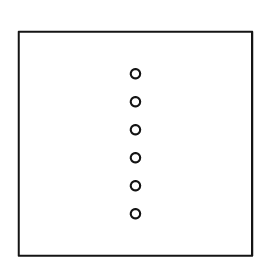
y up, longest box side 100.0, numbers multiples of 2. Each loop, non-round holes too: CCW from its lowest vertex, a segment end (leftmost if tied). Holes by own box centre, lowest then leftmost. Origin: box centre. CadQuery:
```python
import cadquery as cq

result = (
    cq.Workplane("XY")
    .moveTo(-50.0, -48.0)
    .lineTo(50.0, -48.0)
    .lineTo(50.0, 48.0)
    .lineTo(-50.0, 48.0)
    .close()
    .moveTo(0.0, -30.0)
    .circle(2.0)
    .moveTo(0.0, -18.0)
    .circle(2.0)
    .moveTo(0.0, -6.0)
    .circle(2.0)
    .moveTo(0.0, 6.0)
    .circle(2.0)
    .moveTo(0.0, 18.0)
    .circle(2.0)
    .moveTo(0.0, 30.0)
    .circle(2.0)
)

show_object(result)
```